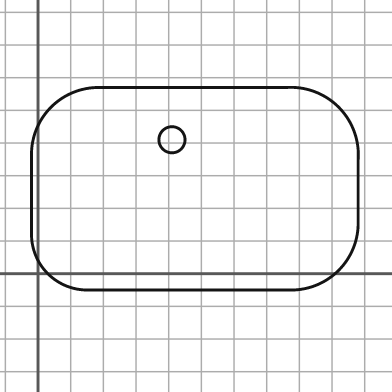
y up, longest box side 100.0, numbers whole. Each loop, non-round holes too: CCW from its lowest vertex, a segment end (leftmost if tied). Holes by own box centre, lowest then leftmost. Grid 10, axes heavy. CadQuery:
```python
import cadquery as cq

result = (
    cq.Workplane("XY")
    .moveTo(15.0, -5.0)
    .lineTo(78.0, -5.0)
    .threePointArc((92.0, 1.0), (98.0, 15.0))
    .lineTo(98.0, 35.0)
    .threePointArc((92.0, 51.0), (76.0, 57.0))
    .lineTo(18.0, 57.0)
    .threePointArc((4.0, 51.0), (-2.0, 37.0))
    .lineTo(-2.0, 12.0)
    .threePointArc((3.0, 0.0), (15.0, -5.0))
    .close()
    .moveTo(41.0, 41.0)
    .circle(4.0)
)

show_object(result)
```